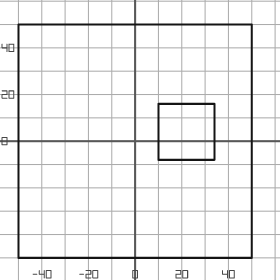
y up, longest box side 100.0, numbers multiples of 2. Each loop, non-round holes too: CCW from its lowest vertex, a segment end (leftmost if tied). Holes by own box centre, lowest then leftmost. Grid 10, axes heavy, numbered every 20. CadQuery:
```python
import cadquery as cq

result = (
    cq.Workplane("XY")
    .moveTo(-50.0, -50.0)
    .lineTo(50.0, -50.0)
    .lineTo(50.0, 50.0)
    .lineTo(-50.0, 50.0)
    .close()
    .moveTo(10.0, -8.0)
    .lineTo(34.0, -8.0)
    .lineTo(34.0, 16.0)
    .lineTo(10.0, 16.0)
    .close()
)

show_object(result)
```